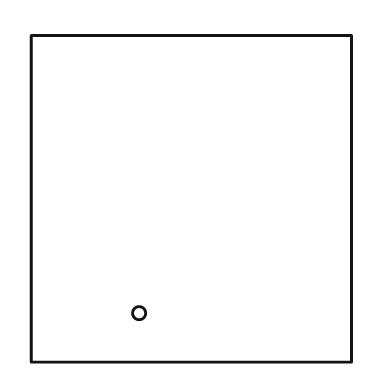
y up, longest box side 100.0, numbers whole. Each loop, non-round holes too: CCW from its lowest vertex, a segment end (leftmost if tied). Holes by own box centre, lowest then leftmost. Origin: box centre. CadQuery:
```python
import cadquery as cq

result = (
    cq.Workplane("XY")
    .moveTo(-49.0, -50.0)
    .lineTo(49.0, -50.0)
    .lineTo(49.0, 50.0)
    .lineTo(-49.0, 50.0)
    .close()
    .moveTo(-16.0, -35.0)
    .circle(2.0)
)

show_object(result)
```